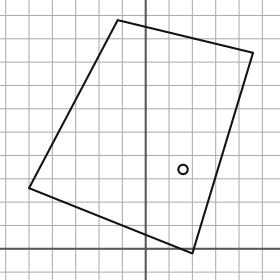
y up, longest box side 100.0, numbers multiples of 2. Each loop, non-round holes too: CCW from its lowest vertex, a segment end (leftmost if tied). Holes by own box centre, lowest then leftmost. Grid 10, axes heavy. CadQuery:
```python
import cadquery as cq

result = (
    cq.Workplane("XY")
    .moveTo(20.0, -2.0)
    .lineTo(46.0, 84.0)
    .lineTo(-12.0, 98.0)
    .lineTo(-50.0, 26.0)
    .close()
    .moveTo(16.0, 34.0)
    .circle(2.0)
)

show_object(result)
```